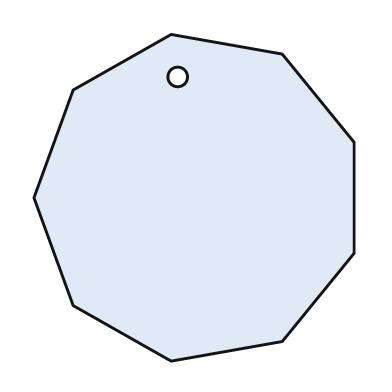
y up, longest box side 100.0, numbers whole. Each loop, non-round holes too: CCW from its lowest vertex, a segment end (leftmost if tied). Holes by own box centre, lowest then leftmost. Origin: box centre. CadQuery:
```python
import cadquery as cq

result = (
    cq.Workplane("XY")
    .moveTo(-7.0, -50.0)
    .lineTo(27.0, -44.0)
    .lineTo(49.0, -17.0)
    .lineTo(49.0, 17.0)
    .lineTo(27.0, 44.0)
    .lineTo(-7.0, 50.0)
    .lineTo(-37.0, 33.0)
    .lineTo(-49.0, 0.0)
    .lineTo(-37.0, -33.0)
    .close()
    .moveTo(-5.0, 37.0)
    .circle(3.0)
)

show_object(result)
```